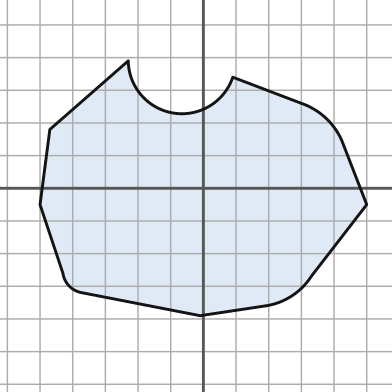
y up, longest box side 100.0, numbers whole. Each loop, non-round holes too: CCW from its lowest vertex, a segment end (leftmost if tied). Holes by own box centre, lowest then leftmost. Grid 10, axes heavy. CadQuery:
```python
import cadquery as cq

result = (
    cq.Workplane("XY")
    .moveTo(-1.0, -39.0)
    .lineTo(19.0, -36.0)
    .threePointArc((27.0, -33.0), (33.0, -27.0))
    .lineTo(50.0, -5.0)
    .lineTo(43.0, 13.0)
    .threePointArc((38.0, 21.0), (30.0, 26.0))
    .lineTo(9.0, 34.0)
    .threePointArc((-9.0, 23.0), (-23.0, 39.0))
    .lineTo(-47.0, 18.0)
    .lineTo(-50.0, -5.0)
    .lineTo(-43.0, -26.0)
    .threePointArc((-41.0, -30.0), (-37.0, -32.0))
    .close()
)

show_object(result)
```